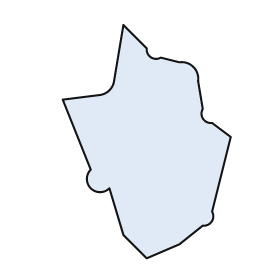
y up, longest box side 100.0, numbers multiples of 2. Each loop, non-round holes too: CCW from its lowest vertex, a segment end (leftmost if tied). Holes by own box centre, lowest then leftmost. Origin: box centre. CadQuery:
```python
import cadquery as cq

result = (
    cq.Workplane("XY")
    .moveTo(0.0, -50.0)
    .lineTo(14.0, -44.0)
    .lineTo(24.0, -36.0)
    .threePointArc((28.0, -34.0), (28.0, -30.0))
    .lineTo(36.0, 2.0)
    .lineTo(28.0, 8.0)
    .threePointArc((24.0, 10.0), (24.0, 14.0))
    .lineTo(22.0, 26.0)
    .threePointArc((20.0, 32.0), (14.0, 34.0))
    .lineTo(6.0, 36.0)
    .threePointArc((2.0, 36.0), (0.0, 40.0))
    .lineTo(-10.0, 50.0)
    .lineTo(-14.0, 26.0)
    .threePointArc((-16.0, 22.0), (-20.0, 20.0))
    .lineTo(-36.0, 18.0)
    .lineTo(-24.0, -12.0)
    .threePointArc((-24.0, -20.0), (-16.0, -20.0))
    .lineTo(-10.0, -40.0)
    .close()
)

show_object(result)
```